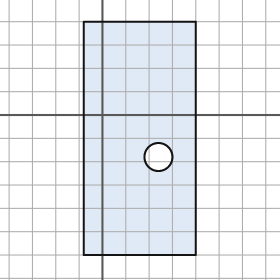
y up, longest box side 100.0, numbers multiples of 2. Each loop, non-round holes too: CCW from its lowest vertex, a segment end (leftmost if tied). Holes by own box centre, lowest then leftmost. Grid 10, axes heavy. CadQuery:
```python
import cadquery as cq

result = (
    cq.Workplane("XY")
    .moveTo(-8.0, -60.0)
    .lineTo(40.0, -60.0)
    .lineTo(40.0, 40.0)
    .lineTo(-8.0, 40.0)
    .close()
    .moveTo(24.0, -18.0)
    .circle(6.0)
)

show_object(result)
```